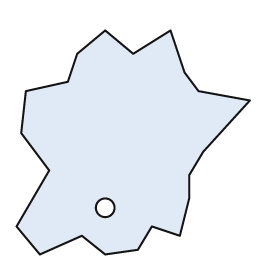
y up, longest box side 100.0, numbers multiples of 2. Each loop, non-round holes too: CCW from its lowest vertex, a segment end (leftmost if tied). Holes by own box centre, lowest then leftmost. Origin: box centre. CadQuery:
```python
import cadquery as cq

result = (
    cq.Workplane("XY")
    .moveTo(-40.0, -48.0)
    .lineTo(-22.0, -40.0)
    .lineTo(-12.0, -48.0)
    .lineTo(2.0, -46.0)
    .lineTo(8.0, -36.0)
    .lineTo(20.0, -40.0)
    .lineTo(24.0, -24.0)
    .lineTo(24.0, -14.0)
    .lineTo(30.0, -4.0)
    .lineTo(50.0, 18.0)
    .lineTo(28.0, 22.0)
    .lineTo(22.0, 30.0)
    .lineTo(16.0, 48.0)
    .lineTo(0.0, 38.0)
    .lineTo(-12.0, 48.0)
    .lineTo(-24.0, 38.0)
    .lineTo(-28.0, 26.0)
    .lineTo(-46.0, 22.0)
    .lineTo(-48.0, 4.0)
    .lineTo(-36.0, -12.0)
    .lineTo(-50.0, -36.0)
    .close()
    .moveTo(-12.0, -28.0)
    .circle(4.0)
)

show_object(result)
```